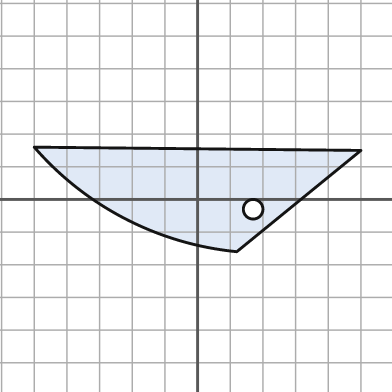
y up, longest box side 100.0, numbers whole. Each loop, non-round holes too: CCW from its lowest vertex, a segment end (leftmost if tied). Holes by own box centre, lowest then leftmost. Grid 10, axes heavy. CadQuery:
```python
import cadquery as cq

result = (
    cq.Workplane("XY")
    .moveTo(12.0, -16.0)
    .lineTo(50.0, 15.0)
    .lineTo(-50.0, 16.0)
    .threePointArc((-22.0, -6.0), (12.0, -16.0))
    .close()
    .moveTo(17.0, -3.0)
    .circle(3.0)
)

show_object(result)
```